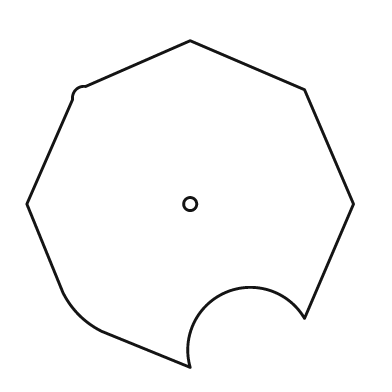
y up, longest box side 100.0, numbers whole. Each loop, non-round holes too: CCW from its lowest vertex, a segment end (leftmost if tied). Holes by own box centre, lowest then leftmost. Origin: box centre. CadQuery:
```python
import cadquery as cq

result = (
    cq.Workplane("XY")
    .moveTo(0.0, -50.0)
    .threePointArc((11.0, -27.0), (35.0, -35.0))
    .lineTo(50.0, 0.0)
    .lineTo(35.0, 35.0)
    .lineTo(0.0, 50.0)
    .lineTo(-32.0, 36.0)
    .threePointArc((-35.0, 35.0), (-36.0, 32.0))
    .lineTo(-50.0, 0.0)
    .lineTo(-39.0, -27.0)
    .threePointArc((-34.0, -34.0), (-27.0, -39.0))
    .close()
    .moveTo(0.0, 0.0)
    .circle(2.0)
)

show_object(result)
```